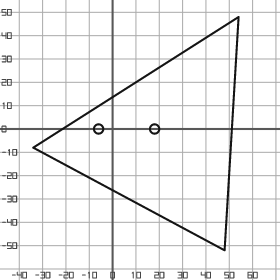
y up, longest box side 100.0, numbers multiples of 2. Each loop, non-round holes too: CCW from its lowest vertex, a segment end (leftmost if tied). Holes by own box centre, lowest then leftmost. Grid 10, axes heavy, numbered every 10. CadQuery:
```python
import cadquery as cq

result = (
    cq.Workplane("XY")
    .moveTo(48.0, -52.0)
    .lineTo(54.0, 48.0)
    .lineTo(-34.0, -8.0)
    .close()
    .moveTo(-6.0, 0.0)
    .circle(2.0)
    .moveTo(18.0, 0.0)
    .circle(2.0)
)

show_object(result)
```